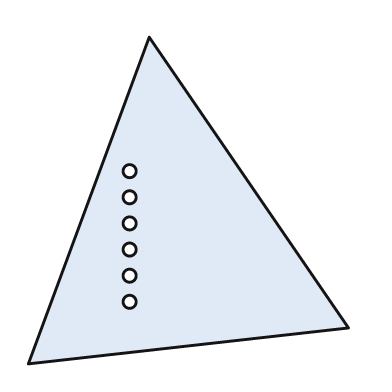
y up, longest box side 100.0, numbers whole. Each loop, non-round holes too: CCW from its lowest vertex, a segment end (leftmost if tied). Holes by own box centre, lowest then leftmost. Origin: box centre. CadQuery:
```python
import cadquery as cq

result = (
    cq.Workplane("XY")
    .moveTo(-49.0, -50.0)
    .lineTo(49.0, -39.0)
    .lineTo(-12.0, 50.0)
    .close()
    .moveTo(-18.0, -31.0)
    .circle(2.0)
    .moveTo(-18.0, -23.0)
    .circle(2.0)
    .moveTo(-18.0, -15.0)
    .circle(2.0)
    .moveTo(-18.0, -7.0)
    .circle(2.0)
    .moveTo(-18.0, 1.0)
    .circle(2.0)
    .moveTo(-18.0, 9.0)
    .circle(2.0)
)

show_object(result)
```